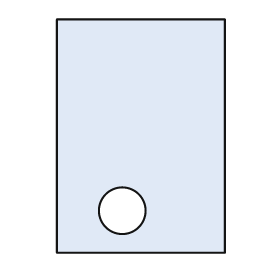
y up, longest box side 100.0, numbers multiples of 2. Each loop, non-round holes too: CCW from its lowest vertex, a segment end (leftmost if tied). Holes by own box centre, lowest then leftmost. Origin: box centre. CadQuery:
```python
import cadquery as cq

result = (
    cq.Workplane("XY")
    .moveTo(-36.0, -50.0)
    .lineTo(36.0, -50.0)
    .lineTo(36.0, 50.0)
    .lineTo(-36.0, 50.0)
    .close()
    .moveTo(-8.0, -32.0)
    .circle(10.0)
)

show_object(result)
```